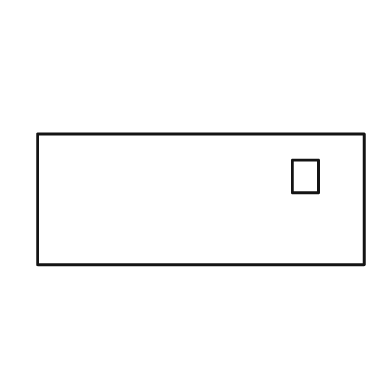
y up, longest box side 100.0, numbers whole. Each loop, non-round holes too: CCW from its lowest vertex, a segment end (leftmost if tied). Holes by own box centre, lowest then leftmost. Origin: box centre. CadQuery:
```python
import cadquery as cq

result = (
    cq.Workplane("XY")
    .moveTo(-50.0, -20.0)
    .lineTo(50.0, -20.0)
    .lineTo(50.0, 20.0)
    .lineTo(-50.0, 20.0)
    .close()
    .moveTo(28.0, 2.0)
    .lineTo(36.0, 2.0)
    .lineTo(36.0, 12.0)
    .lineTo(28.0, 12.0)
    .close()
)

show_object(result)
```